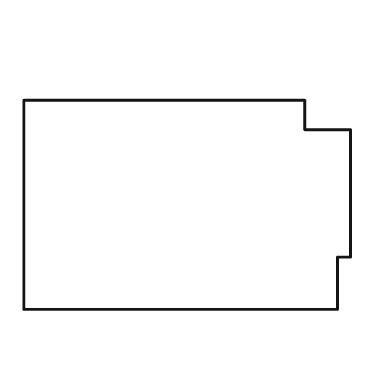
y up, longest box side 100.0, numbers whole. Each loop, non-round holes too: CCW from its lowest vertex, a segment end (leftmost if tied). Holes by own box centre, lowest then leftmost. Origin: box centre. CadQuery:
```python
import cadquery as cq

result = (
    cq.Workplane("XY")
    .moveTo(-50.0, -32.0)
    .lineTo(46.0, -32.0)
    .lineTo(46.0, -16.0)
    .lineTo(50.0, -16.0)
    .lineTo(50.0, 23.0)
    .lineTo(36.0, 23.0)
    .lineTo(36.0, 32.0)
    .lineTo(-50.0, 32.0)
    .close()
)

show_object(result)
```